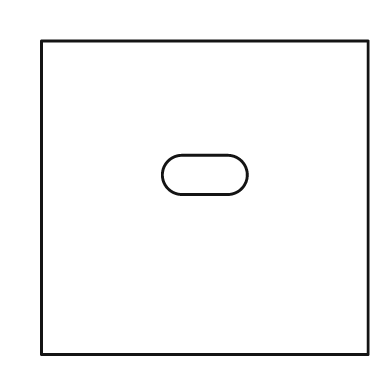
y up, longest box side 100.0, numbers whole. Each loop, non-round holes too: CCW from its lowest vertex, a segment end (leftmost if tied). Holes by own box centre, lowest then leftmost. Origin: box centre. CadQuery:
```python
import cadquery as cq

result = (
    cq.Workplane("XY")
    .moveTo(-50.0, -48.0)
    .lineTo(50.0, -48.0)
    .lineTo(50.0, 48.0)
    .lineTo(-50.0, 48.0)
    .close()
    .moveTo(-7.0, 1.0)
    .lineTo(7.0, 1.0)
    .threePointArc((13.0, 7.0), (7.0, 13.0))
    .lineTo(-7.0, 13.0)
    .threePointArc((-13.0, 7.0), (-7.0, 1.0))
    .close()
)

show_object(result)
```